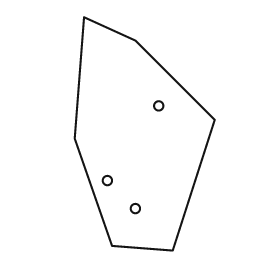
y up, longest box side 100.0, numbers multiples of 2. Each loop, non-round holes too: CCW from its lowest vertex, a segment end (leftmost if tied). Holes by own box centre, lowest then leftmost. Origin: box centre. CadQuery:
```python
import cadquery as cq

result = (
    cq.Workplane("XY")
    .moveTo(12.0, -50.0)
    .lineTo(30.0, 6.0)
    .lineTo(-4.0, 40.0)
    .lineTo(-26.0, 50.0)
    .lineTo(-30.0, -2.0)
    .lineTo(-14.0, -48.0)
    .close()
    .moveTo(-4.0, -32.0)
    .circle(2.0)
    .moveTo(-16.0, -20.0)
    .circle(2.0)
    .moveTo(6.0, 12.0)
    .circle(2.0)
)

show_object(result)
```